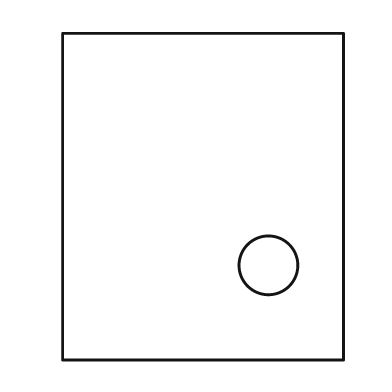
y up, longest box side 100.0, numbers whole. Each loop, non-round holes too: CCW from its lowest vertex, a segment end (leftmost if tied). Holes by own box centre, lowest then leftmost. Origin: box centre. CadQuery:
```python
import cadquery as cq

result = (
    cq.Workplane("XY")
    .moveTo(-43.0, -50.0)
    .lineTo(43.0, -50.0)
    .lineTo(43.0, 50.0)
    .lineTo(-43.0, 50.0)
    .close()
    .moveTo(20.0, -21.0)
    .circle(9.0)
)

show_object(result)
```